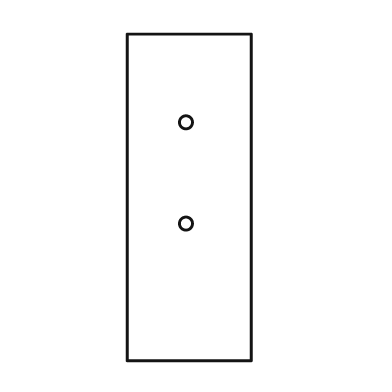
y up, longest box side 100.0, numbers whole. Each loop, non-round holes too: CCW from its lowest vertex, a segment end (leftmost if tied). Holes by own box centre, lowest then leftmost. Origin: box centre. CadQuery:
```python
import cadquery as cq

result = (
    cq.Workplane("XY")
    .moveTo(-19.0, -50.0)
    .lineTo(19.0, -50.0)
    .lineTo(19.0, 50.0)
    .lineTo(-19.0, 50.0)
    .close()
    .moveTo(-1.0, -8.0)
    .circle(2.0)
    .moveTo(-1.0, 23.0)
    .circle(2.0)
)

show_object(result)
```